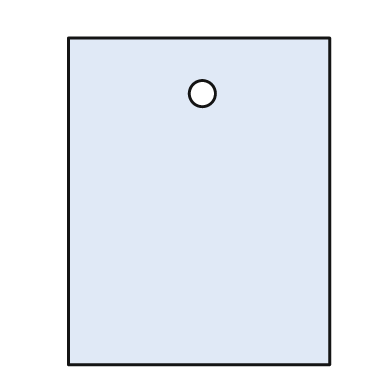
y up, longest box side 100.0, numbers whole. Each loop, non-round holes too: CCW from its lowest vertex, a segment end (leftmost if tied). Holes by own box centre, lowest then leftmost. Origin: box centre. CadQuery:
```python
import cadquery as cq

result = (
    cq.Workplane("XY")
    .moveTo(-40.0, -50.0)
    .lineTo(40.0, -50.0)
    .lineTo(40.0, 50.0)
    .lineTo(-40.0, 50.0)
    .close()
    .moveTo(1.0, 33.0)
    .circle(4.0)
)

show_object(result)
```